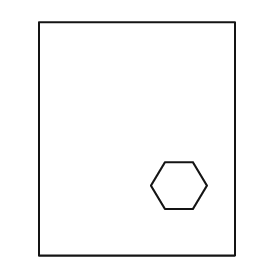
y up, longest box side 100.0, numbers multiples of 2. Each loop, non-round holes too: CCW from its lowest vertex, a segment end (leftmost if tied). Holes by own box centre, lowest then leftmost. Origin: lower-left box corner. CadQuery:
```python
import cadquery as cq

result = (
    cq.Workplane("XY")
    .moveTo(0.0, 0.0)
    .lineTo(84.0, 0.0)
    .lineTo(84.0, 100.0)
    .lineTo(0.0, 100.0)
    .close()
    .moveTo(54.0, 20.0)
    .lineTo(66.0, 20.0)
    .lineTo(72.0, 30.0)
    .lineTo(66.0, 40.0)
    .lineTo(54.0, 40.0)
    .lineTo(48.0, 30.0)
    .close()
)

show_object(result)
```